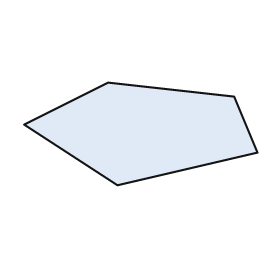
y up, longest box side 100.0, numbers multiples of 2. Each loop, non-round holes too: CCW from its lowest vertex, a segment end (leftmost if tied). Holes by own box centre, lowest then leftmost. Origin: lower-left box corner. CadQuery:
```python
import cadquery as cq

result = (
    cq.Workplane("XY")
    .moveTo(40.0, 0.0)
    .lineTo(100.0, 14.0)
    .lineTo(90.0, 38.0)
    .lineTo(36.0, 44.0)
    .lineTo(0.0, 26.0)
    .close()
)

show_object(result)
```